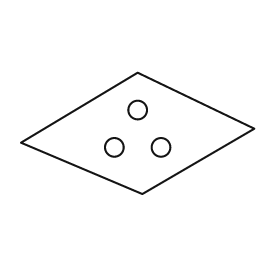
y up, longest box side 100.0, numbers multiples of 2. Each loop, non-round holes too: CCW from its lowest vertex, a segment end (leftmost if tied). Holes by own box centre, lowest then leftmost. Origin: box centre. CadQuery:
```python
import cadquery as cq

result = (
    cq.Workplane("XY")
    .moveTo(2.0, -26.0)
    .lineTo(50.0, 2.0)
    .lineTo(0.0, 26.0)
    .lineTo(-50.0, -4.0)
    .close()
    .moveTo(-10.0, -6.0)
    .circle(4.0)
    .moveTo(10.0, -6.0)
    .circle(4.0)
    .moveTo(0.0, 10.0)
    .circle(4.0)
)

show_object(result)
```